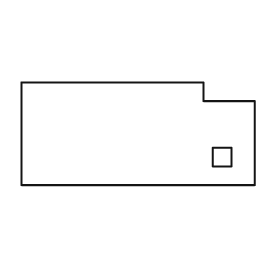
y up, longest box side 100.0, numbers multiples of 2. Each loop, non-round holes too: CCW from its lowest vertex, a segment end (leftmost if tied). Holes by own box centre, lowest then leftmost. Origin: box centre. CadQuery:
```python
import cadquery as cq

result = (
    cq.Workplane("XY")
    .moveTo(-50.0, -22.0)
    .lineTo(50.0, -22.0)
    .lineTo(50.0, 14.0)
    .lineTo(28.0, 14.0)
    .lineTo(28.0, 22.0)
    .lineTo(-50.0, 22.0)
    .close()
    .moveTo(32.0, -14.0)
    .lineTo(40.0, -14.0)
    .lineTo(40.0, -6.0)
    .lineTo(32.0, -6.0)
    .close()
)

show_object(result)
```